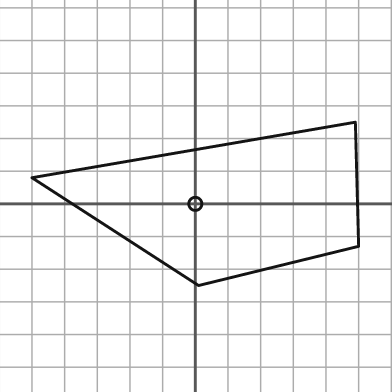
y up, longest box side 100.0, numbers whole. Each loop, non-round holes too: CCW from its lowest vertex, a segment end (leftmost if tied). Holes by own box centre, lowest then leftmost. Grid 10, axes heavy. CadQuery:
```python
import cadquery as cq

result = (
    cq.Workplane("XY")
    .moveTo(1.0, -25.0)
    .lineTo(50.0, -13.0)
    .lineTo(49.0, 25.0)
    .lineTo(-50.0, 8.0)
    .close()
    .moveTo(0.0, 0.0)
    .circle(2.0)
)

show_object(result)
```